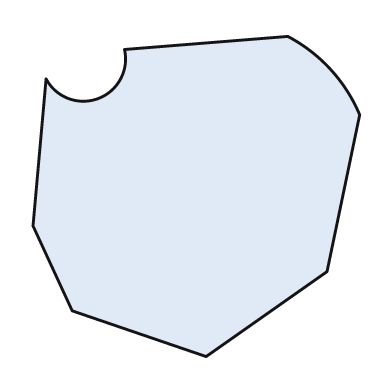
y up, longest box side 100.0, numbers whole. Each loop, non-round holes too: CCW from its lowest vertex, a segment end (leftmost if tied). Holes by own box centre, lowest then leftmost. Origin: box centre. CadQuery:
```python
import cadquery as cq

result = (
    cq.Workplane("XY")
    .moveTo(3.0, -49.0)
    .lineTo(40.0, -23.0)
    .lineTo(50.0, 25.0)
    .threePointArc((41.0, 39.0), (28.0, 49.0))
    .lineTo(-22.0, 45.0)
    .threePointArc((-30.0, 30.0), (-46.0, 36.0))
    .lineTo(-50.0, -9.0)
    .lineTo(-38.0, -35.0)
    .close()
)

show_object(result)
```